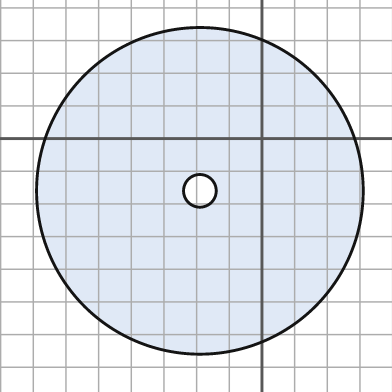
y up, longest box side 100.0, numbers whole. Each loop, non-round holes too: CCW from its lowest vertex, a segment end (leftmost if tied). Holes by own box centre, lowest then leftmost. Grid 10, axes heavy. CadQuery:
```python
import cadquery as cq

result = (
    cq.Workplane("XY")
    .moveTo(-19.0, -16.0)
    .circle(50.0)
    .moveTo(-19.0, -16.0)
    .circle(5.0)
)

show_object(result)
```